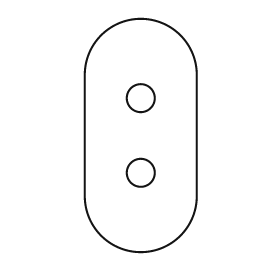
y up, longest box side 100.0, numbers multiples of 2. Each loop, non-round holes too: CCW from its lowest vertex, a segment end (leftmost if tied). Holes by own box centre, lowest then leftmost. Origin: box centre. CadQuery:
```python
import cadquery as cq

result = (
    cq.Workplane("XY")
    .moveTo(-24.0, -26.0)
    .threePointArc((0.0, -50.0), (24.0, -26.0))
    .lineTo(24.0, 26.0)
    .threePointArc((0.0, 50.0), (-24.0, 26.0))
    .close()
    .moveTo(0.0, -16.0)
    .circle(6.0)
    .moveTo(0.0, 16.0)
    .circle(6.0)
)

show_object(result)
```